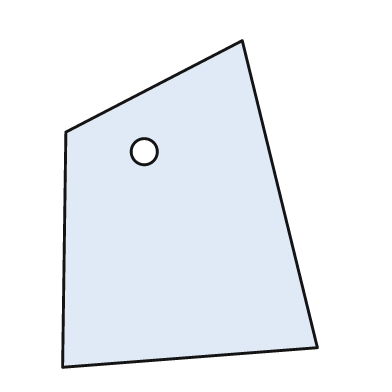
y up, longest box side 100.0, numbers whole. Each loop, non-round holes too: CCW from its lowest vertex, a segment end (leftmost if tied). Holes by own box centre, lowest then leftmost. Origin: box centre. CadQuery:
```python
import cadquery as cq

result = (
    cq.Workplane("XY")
    .moveTo(-39.0, -50.0)
    .lineTo(39.0, -44.0)
    .lineTo(16.0, 50.0)
    .lineTo(-38.0, 22.0)
    .close()
    .moveTo(-14.0, 16.0)
    .circle(4.0)
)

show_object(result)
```